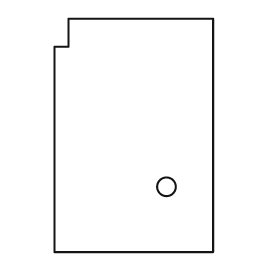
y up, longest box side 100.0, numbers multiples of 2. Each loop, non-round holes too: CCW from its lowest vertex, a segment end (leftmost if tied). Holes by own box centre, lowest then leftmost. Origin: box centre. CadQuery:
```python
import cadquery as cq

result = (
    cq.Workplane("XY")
    .moveTo(-34.0, -50.0)
    .lineTo(34.0, -50.0)
    .lineTo(34.0, 50.0)
    .lineTo(-28.0, 50.0)
    .lineTo(-28.0, 38.0)
    .lineTo(-34.0, 38.0)
    .close()
    .moveTo(14.0, -22.0)
    .circle(4.0)
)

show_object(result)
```